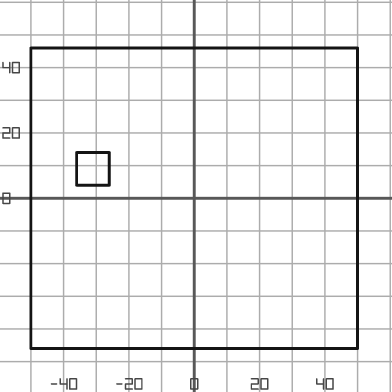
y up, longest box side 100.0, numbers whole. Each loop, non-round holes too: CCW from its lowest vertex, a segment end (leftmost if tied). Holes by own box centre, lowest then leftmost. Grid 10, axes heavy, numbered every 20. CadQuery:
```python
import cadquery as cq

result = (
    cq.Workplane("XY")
    .moveTo(-50.0, -46.0)
    .lineTo(50.0, -46.0)
    .lineTo(50.0, 46.0)
    .lineTo(-50.0, 46.0)
    .close()
    .moveTo(-36.0, 4.0)
    .lineTo(-26.0, 4.0)
    .lineTo(-26.0, 14.0)
    .lineTo(-36.0, 14.0)
    .close()
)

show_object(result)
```